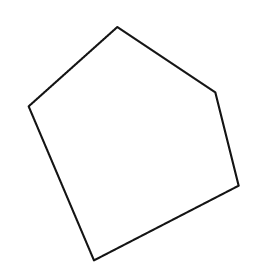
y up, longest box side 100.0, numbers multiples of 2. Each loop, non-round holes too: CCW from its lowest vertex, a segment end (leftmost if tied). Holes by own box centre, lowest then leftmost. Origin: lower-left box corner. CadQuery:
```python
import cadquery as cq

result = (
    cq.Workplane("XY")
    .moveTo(28.0, 0.0)
    .lineTo(90.0, 32.0)
    .lineTo(80.0, 72.0)
    .lineTo(38.0, 100.0)
    .lineTo(0.0, 66.0)
    .close()
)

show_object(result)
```